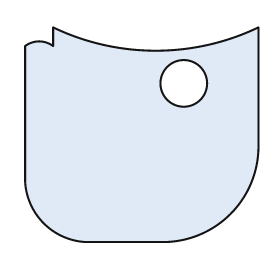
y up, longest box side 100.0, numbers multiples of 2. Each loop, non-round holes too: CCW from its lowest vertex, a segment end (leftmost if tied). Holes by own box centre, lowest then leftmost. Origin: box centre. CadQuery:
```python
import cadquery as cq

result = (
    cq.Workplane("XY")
    .moveTo(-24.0, -46.0)
    .lineTo(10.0, -46.0)
    .threePointArc((38.0, -34.0), (50.0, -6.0))
    .lineTo(50.0, 46.0)
    .threePointArc((6.0, 36.0), (-38.0, 46.0))
    .lineTo(-38.0, 38.0)
    .threePointArc((-44.0, 40.0), (-50.0, 38.0))
    .lineTo(-50.0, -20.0)
    .threePointArc((-42.0, -38.0), (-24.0, -46.0))
    .close()
    .moveTo(18.0, 22.0)
    .circle(10.0)
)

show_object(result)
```